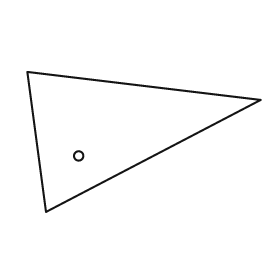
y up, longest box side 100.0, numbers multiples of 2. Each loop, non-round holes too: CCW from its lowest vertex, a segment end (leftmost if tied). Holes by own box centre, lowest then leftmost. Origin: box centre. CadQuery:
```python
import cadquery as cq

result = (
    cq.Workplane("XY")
    .moveTo(-42.0, -30.0)
    .lineTo(50.0, 18.0)
    .lineTo(-50.0, 30.0)
    .close()
    .moveTo(-28.0, -6.0)
    .circle(2.0)
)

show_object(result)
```